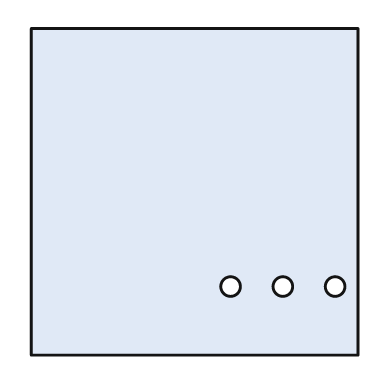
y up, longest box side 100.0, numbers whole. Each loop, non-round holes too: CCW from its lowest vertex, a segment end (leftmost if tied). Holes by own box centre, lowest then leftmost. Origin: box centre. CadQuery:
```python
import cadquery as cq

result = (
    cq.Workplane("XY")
    .moveTo(-50.0, -50.0)
    .lineTo(50.0, -50.0)
    .lineTo(50.0, 50.0)
    .lineTo(-50.0, 50.0)
    .close()
    .moveTo(11.0, -29.0)
    .circle(3.0)
    .moveTo(27.0, -29.0)
    .circle(3.0)
    .moveTo(43.0, -29.0)
    .circle(3.0)
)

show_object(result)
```